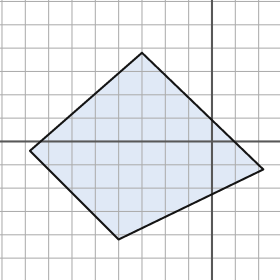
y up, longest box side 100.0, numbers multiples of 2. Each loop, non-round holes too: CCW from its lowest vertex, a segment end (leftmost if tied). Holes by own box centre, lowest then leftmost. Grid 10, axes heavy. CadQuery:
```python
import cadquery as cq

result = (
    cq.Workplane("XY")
    .moveTo(-40.0, -42.0)
    .lineTo(22.0, -12.0)
    .lineTo(-30.0, 38.0)
    .lineTo(-78.0, -4.0)
    .close()
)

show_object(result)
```